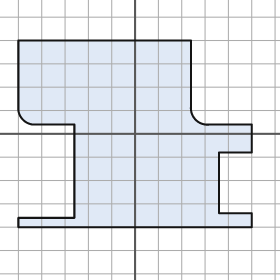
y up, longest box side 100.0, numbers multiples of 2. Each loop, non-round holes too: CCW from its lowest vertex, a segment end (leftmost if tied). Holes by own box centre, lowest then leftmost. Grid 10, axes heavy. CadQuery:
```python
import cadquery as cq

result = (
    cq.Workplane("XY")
    .moveTo(-50.0, -40.0)
    .lineTo(50.0, -40.0)
    .lineTo(50.0, -34.0)
    .lineTo(36.0, -34.0)
    .lineTo(36.0, -8.0)
    .lineTo(50.0, -8.0)
    .lineTo(50.0, 4.0)
    .lineTo(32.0, 4.0)
    .threePointArc((26.0, 6.0), (24.0, 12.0))
    .lineTo(24.0, 40.0)
    .lineTo(-50.0, 40.0)
    .lineTo(-50.0, 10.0)
    .threePointArc((-48.0, 6.0), (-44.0, 4.0))
    .lineTo(-26.0, 4.0)
    .lineTo(-26.0, -36.0)
    .lineTo(-50.0, -36.0)
    .close()
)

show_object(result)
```